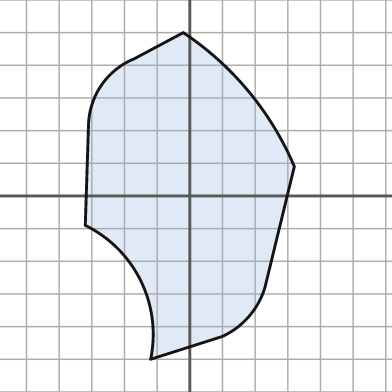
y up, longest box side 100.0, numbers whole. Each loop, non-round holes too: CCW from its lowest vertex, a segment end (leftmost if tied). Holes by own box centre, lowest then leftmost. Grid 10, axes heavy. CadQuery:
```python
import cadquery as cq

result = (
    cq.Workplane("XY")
    .moveTo(-12.0, -50.0)
    .lineTo(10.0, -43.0)
    .threePointArc((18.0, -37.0), (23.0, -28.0))
    .lineTo(32.0, 9.0)
    .threePointArc((18.0, 32.0), (-2.0, 50.0))
    .lineTo(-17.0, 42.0)
    .threePointArc((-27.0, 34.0), (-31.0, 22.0))
    .lineTo(-32.0, -9.0)
    .threePointArc((-15.0, -26.0), (-12.0, -50.0))
    .close()
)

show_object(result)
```